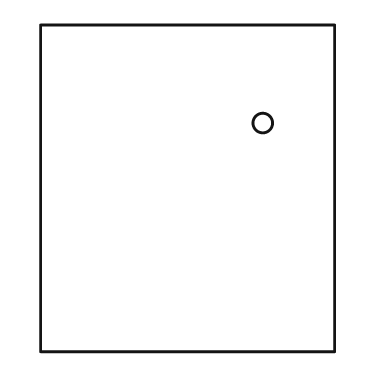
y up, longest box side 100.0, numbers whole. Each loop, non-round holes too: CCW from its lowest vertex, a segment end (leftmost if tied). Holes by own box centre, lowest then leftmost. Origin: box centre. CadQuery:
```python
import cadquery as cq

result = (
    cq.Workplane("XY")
    .moveTo(-45.0, -50.0)
    .lineTo(45.0, -50.0)
    .lineTo(45.0, 50.0)
    .lineTo(-45.0, 50.0)
    .close()
    .moveTo(23.0, 20.0)
    .circle(3.0)
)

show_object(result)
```